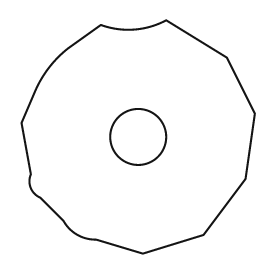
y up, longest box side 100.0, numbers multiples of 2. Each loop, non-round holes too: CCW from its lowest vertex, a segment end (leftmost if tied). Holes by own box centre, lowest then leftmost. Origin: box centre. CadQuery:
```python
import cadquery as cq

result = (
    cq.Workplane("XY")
    .moveTo(2.0, -50.0)
    .lineTo(28.0, -42.0)
    .lineTo(46.0, -18.0)
    .lineTo(50.0, 10.0)
    .lineTo(38.0, 34.0)
    .lineTo(12.0, 50.0)
    .threePointArc((-2.0, 46.0), (-16.0, 48.0))
    .lineTo(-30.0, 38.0)
    .threePointArc((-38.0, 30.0), (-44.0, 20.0))
    .lineTo(-50.0, 6.0)
    .lineTo(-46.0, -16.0)
    .threePointArc((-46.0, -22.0), (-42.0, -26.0))
    .lineTo(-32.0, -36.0)
    .threePointArc((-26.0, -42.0), (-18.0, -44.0))
    .close()
    .moveTo(0.0, 0.0)
    .circle(12.0)
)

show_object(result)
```